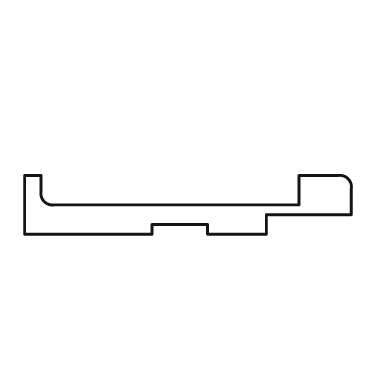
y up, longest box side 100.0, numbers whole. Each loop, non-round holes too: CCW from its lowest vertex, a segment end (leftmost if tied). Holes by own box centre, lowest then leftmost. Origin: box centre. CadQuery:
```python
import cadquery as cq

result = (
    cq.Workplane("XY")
    .moveTo(-50.0, -9.0)
    .lineTo(-11.0, -9.0)
    .lineTo(-11.0, -6.0)
    .lineTo(6.0, -6.0)
    .lineTo(6.0, -9.0)
    .lineTo(24.0, -9.0)
    .lineTo(24.0, -3.0)
    .lineTo(50.0, -3.0)
    .lineTo(50.0, 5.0)
    .threePointArc((49.0, 8.0), (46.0, 9.0))
    .lineTo(34.0, 9.0)
    .lineTo(34.0, 0.0)
    .lineTo(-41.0, 0.0)
    .threePointArc((-44.0, 1.0), (-45.0, 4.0))
    .lineTo(-45.0, 9.0)
    .lineTo(-50.0, 9.0)
    .close()
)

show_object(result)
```